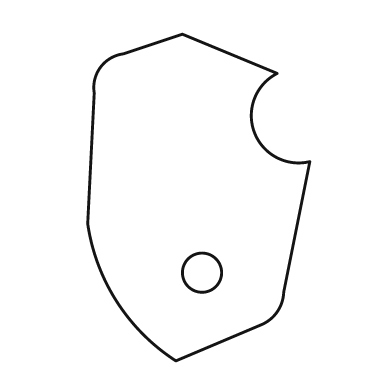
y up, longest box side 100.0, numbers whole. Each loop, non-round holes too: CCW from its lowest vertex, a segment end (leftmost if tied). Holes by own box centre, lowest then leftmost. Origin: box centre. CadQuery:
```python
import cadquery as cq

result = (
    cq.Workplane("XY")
    .moveTo(-7.0, -50.0)
    .lineTo(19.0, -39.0)
    .threePointArc((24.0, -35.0), (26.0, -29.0))
    .lineTo(34.0, 11.0)
    .threePointArc((17.0, 20.0), (24.0, 38.0))
    .lineTo(-5.0, 50.0)
    .lineTo(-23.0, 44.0)
    .threePointArc((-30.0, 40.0), (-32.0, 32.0))
    .lineTo(-34.0, -8.0)
    .threePointArc((-25.0, -32.0), (-7.0, -50.0))
    .close()
    .moveTo(1.0, -23.0)
    .circle(6.0)
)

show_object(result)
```